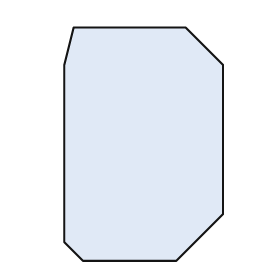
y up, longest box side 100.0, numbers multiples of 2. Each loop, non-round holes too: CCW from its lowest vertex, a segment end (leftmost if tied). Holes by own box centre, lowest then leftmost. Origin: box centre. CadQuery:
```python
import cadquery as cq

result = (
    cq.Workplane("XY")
    .moveTo(-26.0, -50.0)
    .lineTo(14.0, -50.0)
    .lineTo(34.0, -30.0)
    .lineTo(34.0, 34.0)
    .lineTo(18.0, 50.0)
    .lineTo(-30.0, 50.0)
    .lineTo(-34.0, 34.0)
    .lineTo(-34.0, -42.0)
    .close()
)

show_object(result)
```